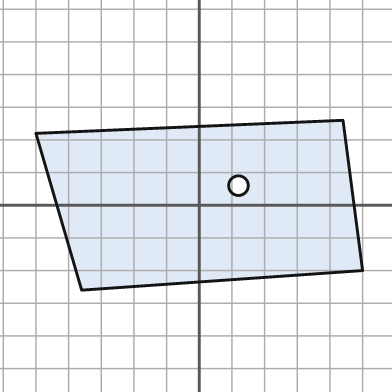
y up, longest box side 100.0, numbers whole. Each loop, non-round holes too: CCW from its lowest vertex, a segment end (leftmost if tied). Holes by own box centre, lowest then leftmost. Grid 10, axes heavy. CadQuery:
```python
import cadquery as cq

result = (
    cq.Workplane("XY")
    .moveTo(-36.0, -26.0)
    .lineTo(50.0, -20.0)
    .lineTo(44.0, 26.0)
    .lineTo(-50.0, 22.0)
    .close()
    .moveTo(12.0, 6.0)
    .circle(3.0)
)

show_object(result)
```